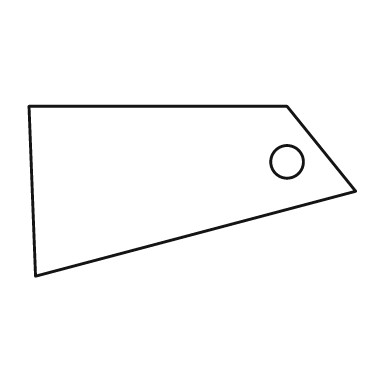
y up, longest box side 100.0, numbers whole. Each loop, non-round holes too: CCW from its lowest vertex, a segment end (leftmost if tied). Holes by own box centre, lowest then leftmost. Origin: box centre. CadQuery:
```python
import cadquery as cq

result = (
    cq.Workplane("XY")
    .moveTo(-48.0, -26.0)
    .lineTo(50.0, 0.0)
    .lineTo(29.0, 26.0)
    .lineTo(-50.0, 26.0)
    .close()
    .moveTo(29.0, 9.0)
    .circle(5.0)
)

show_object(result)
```